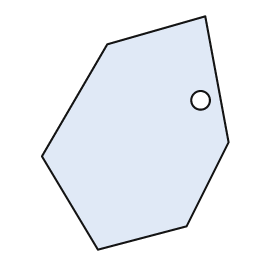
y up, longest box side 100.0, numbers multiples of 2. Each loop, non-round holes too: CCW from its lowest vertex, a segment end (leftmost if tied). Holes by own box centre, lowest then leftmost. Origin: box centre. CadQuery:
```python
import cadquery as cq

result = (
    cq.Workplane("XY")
    .moveTo(-16.0, -50.0)
    .lineTo(22.0, -40.0)
    .lineTo(40.0, -4.0)
    .lineTo(30.0, 50.0)
    .lineTo(-12.0, 38.0)
    .lineTo(-40.0, -10.0)
    .close()
    .moveTo(28.0, 14.0)
    .circle(4.0)
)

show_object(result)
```